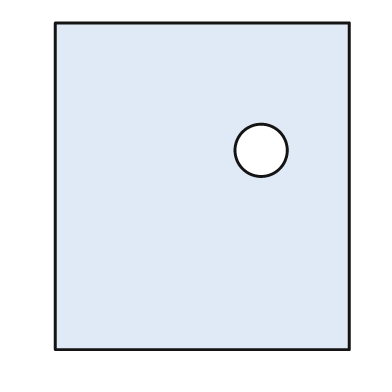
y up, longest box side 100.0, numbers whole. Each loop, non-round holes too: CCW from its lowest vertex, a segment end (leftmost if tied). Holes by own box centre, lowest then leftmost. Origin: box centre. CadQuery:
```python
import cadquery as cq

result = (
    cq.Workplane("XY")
    .moveTo(-45.0, -50.0)
    .lineTo(45.0, -50.0)
    .lineTo(45.0, 50.0)
    .lineTo(-45.0, 50.0)
    .close()
    .moveTo(18.0, 11.0)
    .circle(8.0)
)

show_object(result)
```